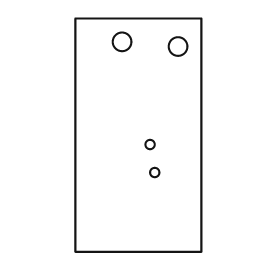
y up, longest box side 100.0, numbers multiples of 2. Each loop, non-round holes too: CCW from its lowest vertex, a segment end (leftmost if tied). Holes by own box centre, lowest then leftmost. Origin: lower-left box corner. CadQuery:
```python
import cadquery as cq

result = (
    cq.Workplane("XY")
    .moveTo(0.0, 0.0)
    .lineTo(54.0, 0.0)
    .lineTo(54.0, 100.0)
    .lineTo(0.0, 100.0)
    .close()
    .moveTo(34.0, 34.0)
    .circle(2.0)
    .moveTo(32.0, 46.0)
    .circle(2.0)
    .moveTo(44.0, 88.0)
    .circle(4.0)
    .moveTo(20.0, 90.0)
    .circle(4.0)
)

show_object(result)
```